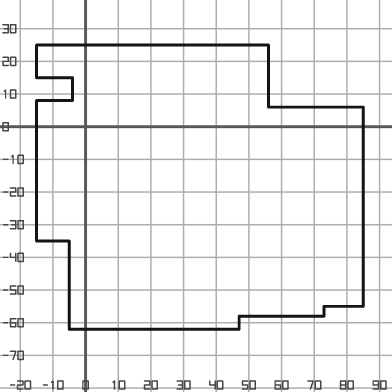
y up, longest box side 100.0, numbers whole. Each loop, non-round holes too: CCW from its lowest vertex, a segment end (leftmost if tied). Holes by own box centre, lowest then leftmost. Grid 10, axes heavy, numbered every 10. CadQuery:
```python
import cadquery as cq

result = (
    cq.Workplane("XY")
    .moveTo(-5.0, -62.0)
    .lineTo(47.0, -62.0)
    .lineTo(47.0, -58.0)
    .lineTo(73.0, -58.0)
    .lineTo(73.0, -55.0)
    .lineTo(85.0, -55.0)
    .lineTo(85.0, 6.0)
    .lineTo(56.0, 6.0)
    .lineTo(56.0, 25.0)
    .lineTo(-15.0, 25.0)
    .lineTo(-15.0, 15.0)
    .lineTo(-4.0, 15.0)
    .lineTo(-4.0, 8.0)
    .lineTo(-15.0, 8.0)
    .lineTo(-15.0, -35.0)
    .lineTo(-5.0, -35.0)
    .close()
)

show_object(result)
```